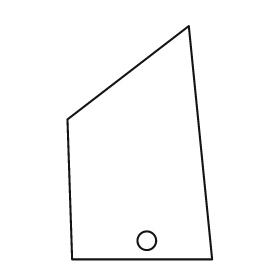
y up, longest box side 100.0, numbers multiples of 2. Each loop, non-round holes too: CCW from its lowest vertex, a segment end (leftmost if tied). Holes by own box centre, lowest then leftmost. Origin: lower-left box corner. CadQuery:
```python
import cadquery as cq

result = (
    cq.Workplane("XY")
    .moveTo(2.0, 0.0)
    .lineTo(62.0, 0.0)
    .lineTo(52.0, 100.0)
    .lineTo(0.0, 60.0)
    .close()
    .moveTo(34.0, 8.0)
    .circle(4.0)
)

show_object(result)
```